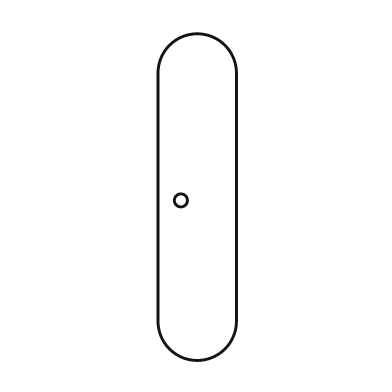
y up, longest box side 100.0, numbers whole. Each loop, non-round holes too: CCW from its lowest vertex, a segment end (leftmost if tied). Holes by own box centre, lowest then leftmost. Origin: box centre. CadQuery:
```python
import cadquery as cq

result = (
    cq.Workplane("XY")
    .moveTo(-12.0, -38.0)
    .threePointArc((0.0, -50.0), (12.0, -38.0))
    .lineTo(12.0, 38.0)
    .threePointArc((0.0, 50.0), (-12.0, 38.0))
    .close()
    .moveTo(-5.0, -1.0)
    .circle(2.0)
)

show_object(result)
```